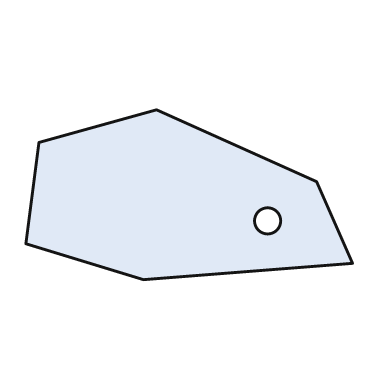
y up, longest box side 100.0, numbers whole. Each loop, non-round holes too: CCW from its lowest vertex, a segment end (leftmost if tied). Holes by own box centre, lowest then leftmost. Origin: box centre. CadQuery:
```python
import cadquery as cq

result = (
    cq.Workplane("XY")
    .moveTo(-14.0, -26.0)
    .lineTo(50.0, -21.0)
    .lineTo(39.0, 4.0)
    .lineTo(-10.0, 26.0)
    .lineTo(-46.0, 16.0)
    .lineTo(-50.0, -15.0)
    .close()
    .moveTo(24.0, -8.0)
    .circle(4.0)
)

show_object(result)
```